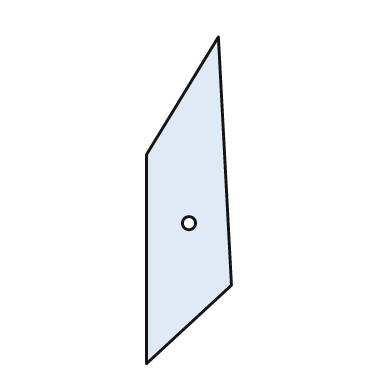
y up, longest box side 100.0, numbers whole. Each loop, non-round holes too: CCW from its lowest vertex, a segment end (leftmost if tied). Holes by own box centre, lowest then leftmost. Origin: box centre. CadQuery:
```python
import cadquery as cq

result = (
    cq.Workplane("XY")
    .moveTo(-13.0, -50.0)
    .lineTo(13.0, -26.0)
    .lineTo(9.0, 50.0)
    .lineTo(-13.0, 14.0)
    .close()
    .moveTo(0.0, -7.0)
    .circle(2.0)
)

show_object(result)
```